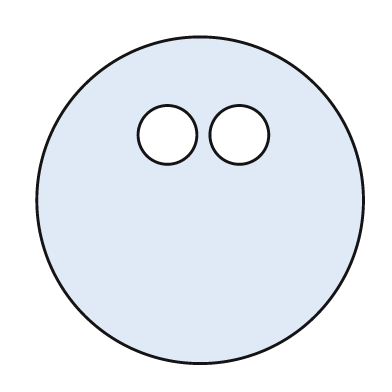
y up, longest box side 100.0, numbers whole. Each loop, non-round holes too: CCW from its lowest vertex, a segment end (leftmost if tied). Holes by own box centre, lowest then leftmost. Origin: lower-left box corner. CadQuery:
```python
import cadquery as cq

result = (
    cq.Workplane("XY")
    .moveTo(50.0, 50.0)
    .circle(50.0)
    .moveTo(40.0, 70.0)
    .circle(9.0)
    .moveTo(62.0, 70.0)
    .circle(9.0)
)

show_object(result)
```